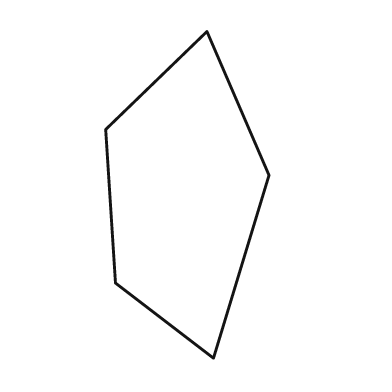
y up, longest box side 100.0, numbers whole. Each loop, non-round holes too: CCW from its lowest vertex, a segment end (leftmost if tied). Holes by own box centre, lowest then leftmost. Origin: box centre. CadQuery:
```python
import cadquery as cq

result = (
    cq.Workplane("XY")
    .moveTo(8.0, -50.0)
    .lineTo(25.0, 6.0)
    .lineTo(6.0, 50.0)
    .lineTo(-25.0, 20.0)
    .lineTo(-22.0, -27.0)
    .close()
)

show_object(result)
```